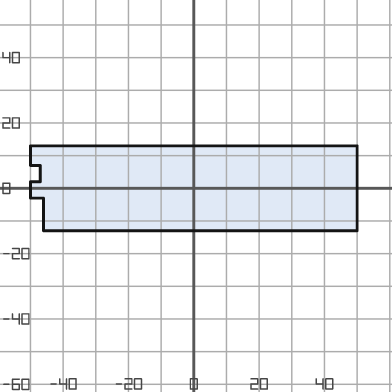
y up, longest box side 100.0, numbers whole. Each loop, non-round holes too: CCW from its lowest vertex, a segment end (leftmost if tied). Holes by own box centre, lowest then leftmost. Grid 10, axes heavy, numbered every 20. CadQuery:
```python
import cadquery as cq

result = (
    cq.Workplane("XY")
    .moveTo(-46.0, -13.0)
    .lineTo(50.0, -13.0)
    .lineTo(50.0, 13.0)
    .lineTo(-50.0, 13.0)
    .lineTo(-50.0, 7.0)
    .lineTo(-47.0, 7.0)
    .lineTo(-47.0, 2.0)
    .lineTo(-50.0, 2.0)
    .lineTo(-50.0, -3.0)
    .lineTo(-46.0, -3.0)
    .close()
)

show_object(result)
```